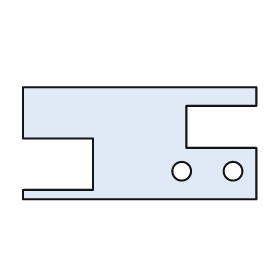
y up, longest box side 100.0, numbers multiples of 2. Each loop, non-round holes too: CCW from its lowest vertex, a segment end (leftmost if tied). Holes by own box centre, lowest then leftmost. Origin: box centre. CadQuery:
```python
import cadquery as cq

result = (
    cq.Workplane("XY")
    .moveTo(-50.0, -24.0)
    .lineTo(50.0, -24.0)
    .lineTo(50.0, -2.0)
    .lineTo(20.0, -2.0)
    .lineTo(20.0, 16.0)
    .lineTo(50.0, 16.0)
    .lineTo(50.0, 24.0)
    .lineTo(-50.0, 24.0)
    .lineTo(-50.0, 2.0)
    .lineTo(-20.0, 2.0)
    .lineTo(-20.0, -20.0)
    .lineTo(-50.0, -20.0)
    .close()
    .moveTo(18.0, -12.0)
    .circle(4.0)
    .moveTo(40.0, -12.0)
    .circle(4.0)
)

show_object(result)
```